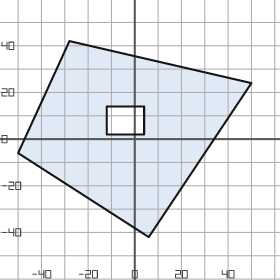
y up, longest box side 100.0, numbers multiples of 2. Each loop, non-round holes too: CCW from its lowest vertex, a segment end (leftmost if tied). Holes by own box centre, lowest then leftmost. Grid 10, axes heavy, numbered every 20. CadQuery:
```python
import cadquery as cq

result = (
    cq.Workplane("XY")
    .moveTo(6.0, -42.0)
    .lineTo(50.0, 24.0)
    .lineTo(-28.0, 42.0)
    .lineTo(-50.0, -6.0)
    .close()
    .moveTo(-12.0, 2.0)
    .lineTo(4.0, 2.0)
    .lineTo(4.0, 14.0)
    .lineTo(-12.0, 14.0)
    .close()
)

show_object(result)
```